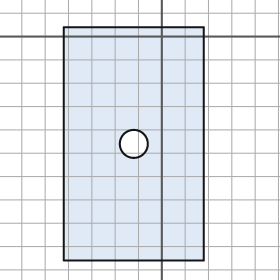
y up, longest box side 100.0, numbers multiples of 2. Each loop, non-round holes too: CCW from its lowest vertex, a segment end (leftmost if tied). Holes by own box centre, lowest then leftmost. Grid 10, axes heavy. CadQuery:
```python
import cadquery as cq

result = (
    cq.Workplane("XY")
    .moveTo(-42.0, -96.0)
    .lineTo(18.0, -96.0)
    .lineTo(18.0, 4.0)
    .lineTo(-42.0, 4.0)
    .close()
    .moveTo(-12.0, -46.0)
    .circle(6.0)
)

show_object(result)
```